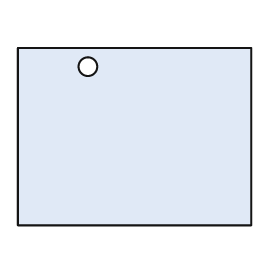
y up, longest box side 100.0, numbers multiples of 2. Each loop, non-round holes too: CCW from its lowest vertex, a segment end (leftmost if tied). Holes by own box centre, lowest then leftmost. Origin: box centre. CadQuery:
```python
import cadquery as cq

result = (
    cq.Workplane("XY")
    .moveTo(-50.0, -38.0)
    .lineTo(50.0, -38.0)
    .lineTo(50.0, 38.0)
    .lineTo(-50.0, 38.0)
    .close()
    .moveTo(-20.0, 30.0)
    .circle(4.0)
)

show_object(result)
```